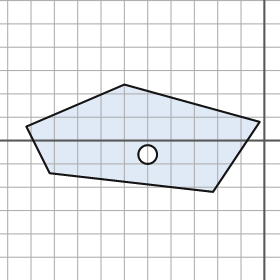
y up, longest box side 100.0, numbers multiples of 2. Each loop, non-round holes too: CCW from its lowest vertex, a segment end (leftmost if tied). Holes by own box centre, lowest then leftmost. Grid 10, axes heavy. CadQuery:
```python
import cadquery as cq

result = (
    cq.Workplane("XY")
    .moveTo(-22.0, -22.0)
    .lineTo(-2.0, 8.0)
    .lineTo(-60.0, 24.0)
    .lineTo(-102.0, 6.0)
    .lineTo(-92.0, -14.0)
    .close()
    .moveTo(-50.0, -6.0)
    .circle(4.0)
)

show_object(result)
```